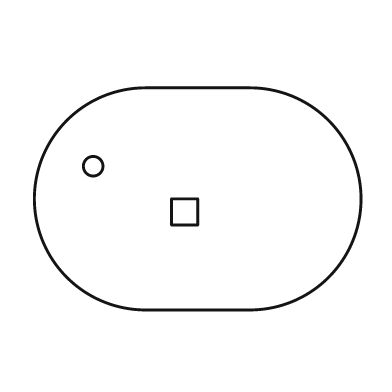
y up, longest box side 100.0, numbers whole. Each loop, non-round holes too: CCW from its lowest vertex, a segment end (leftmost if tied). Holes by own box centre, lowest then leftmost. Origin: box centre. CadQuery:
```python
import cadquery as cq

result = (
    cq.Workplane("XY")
    .moveTo(-16.0, -34.0)
    .lineTo(16.0, -34.0)
    .threePointArc((50.0, 0.0), (16.0, 34.0))
    .lineTo(-16.0, 34.0)
    .threePointArc((-50.0, 0.0), (-16.0, -34.0))
    .close()
    .moveTo(-8.0, -8.0)
    .lineTo(0.0, -8.0)
    .lineTo(0.0, 0.0)
    .lineTo(-8.0, 0.0)
    .close()
    .moveTo(-32.0, 10.0)
    .circle(3.0)
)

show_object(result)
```